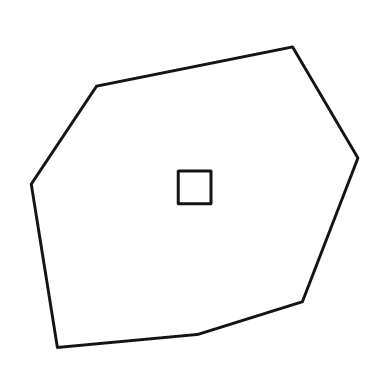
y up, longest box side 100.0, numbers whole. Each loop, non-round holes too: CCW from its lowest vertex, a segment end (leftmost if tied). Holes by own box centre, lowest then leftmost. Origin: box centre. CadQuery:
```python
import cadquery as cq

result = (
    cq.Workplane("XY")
    .moveTo(-42.0, -46.0)
    .lineTo(1.0, -42.0)
    .lineTo(33.0, -32.0)
    .lineTo(50.0, 12.0)
    .lineTo(30.0, 46.0)
    .lineTo(-30.0, 34.0)
    .lineTo(-50.0, 4.0)
    .close()
    .moveTo(-5.0, -2.0)
    .lineTo(5.0, -2.0)
    .lineTo(5.0, 8.0)
    .lineTo(-5.0, 8.0)
    .close()
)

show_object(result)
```